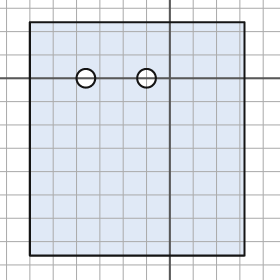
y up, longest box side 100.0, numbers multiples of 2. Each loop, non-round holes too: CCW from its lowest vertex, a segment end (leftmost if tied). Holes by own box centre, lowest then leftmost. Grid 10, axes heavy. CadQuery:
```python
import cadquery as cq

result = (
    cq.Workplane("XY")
    .moveTo(-60.0, -76.0)
    .lineTo(32.0, -76.0)
    .lineTo(32.0, 24.0)
    .lineTo(-60.0, 24.0)
    .close()
    .moveTo(-36.0, 0.0)
    .circle(4.0)
    .moveTo(-10.0, 0.0)
    .circle(4.0)
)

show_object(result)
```